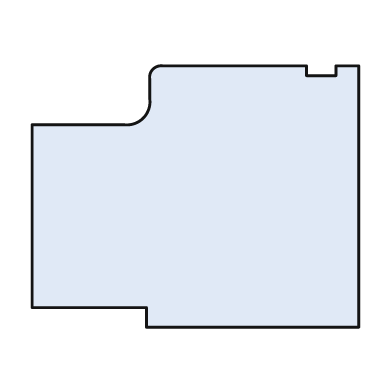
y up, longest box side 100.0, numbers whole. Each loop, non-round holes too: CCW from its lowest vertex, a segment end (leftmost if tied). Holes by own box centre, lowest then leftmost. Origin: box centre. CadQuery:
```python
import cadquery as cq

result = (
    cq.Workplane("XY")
    .moveTo(-15.0, -40.0)
    .lineTo(50.0, -40.0)
    .lineTo(50.0, 40.0)
    .lineTo(43.0, 40.0)
    .lineTo(43.0, 37.0)
    .lineTo(34.0, 37.0)
    .lineTo(34.0, 40.0)
    .lineTo(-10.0, 40.0)
    .threePointArc((-13.0, 39.0), (-14.0, 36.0))
    .lineTo(-14.0, 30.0)
    .threePointArc((-16.0, 24.0), (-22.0, 22.0))
    .lineTo(-50.0, 22.0)
    .lineTo(-50.0, -34.0)
    .lineTo(-15.0, -34.0)
    .close()
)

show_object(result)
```